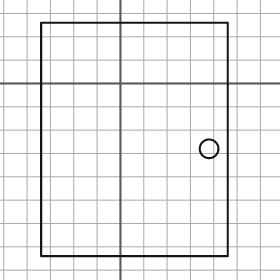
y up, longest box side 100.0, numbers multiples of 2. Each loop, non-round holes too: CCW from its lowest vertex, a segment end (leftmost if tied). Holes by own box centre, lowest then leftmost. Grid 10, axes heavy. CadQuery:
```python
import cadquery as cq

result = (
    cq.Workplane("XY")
    .moveTo(-34.0, -74.0)
    .lineTo(46.0, -74.0)
    .lineTo(46.0, 26.0)
    .lineTo(-34.0, 26.0)
    .close()
    .moveTo(38.0, -28.0)
    .circle(4.0)
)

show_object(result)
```